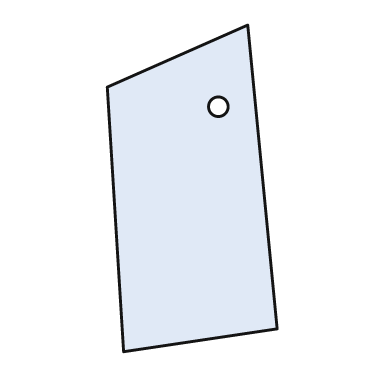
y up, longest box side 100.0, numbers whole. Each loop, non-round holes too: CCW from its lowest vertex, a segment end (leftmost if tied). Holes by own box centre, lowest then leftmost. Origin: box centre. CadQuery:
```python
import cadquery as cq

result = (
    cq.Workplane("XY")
    .moveTo(-21.0, -50.0)
    .lineTo(26.0, -43.0)
    .lineTo(17.0, 50.0)
    .lineTo(-26.0, 31.0)
    .close()
    .moveTo(8.0, 25.0)
    .circle(3.0)
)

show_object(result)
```